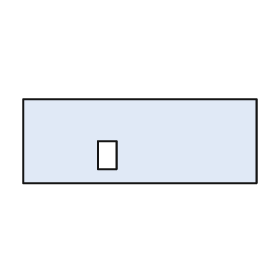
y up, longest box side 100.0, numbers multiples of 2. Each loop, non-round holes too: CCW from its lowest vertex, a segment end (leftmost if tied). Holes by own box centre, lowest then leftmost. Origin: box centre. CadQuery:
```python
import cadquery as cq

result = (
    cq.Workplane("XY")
    .moveTo(-50.0, -18.0)
    .lineTo(50.0, -18.0)
    .lineTo(50.0, 18.0)
    .lineTo(-50.0, 18.0)
    .close()
    .moveTo(-18.0, -12.0)
    .lineTo(-10.0, -12.0)
    .lineTo(-10.0, 0.0)
    .lineTo(-18.0, 0.0)
    .close()
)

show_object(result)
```